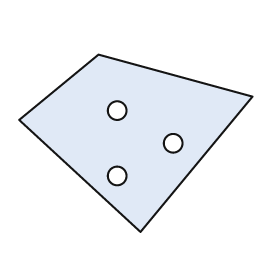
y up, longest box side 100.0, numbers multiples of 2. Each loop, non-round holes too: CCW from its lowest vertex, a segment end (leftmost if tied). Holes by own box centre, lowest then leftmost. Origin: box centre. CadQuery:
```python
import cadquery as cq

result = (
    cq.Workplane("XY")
    .moveTo(2.0, -38.0)
    .lineTo(50.0, 20.0)
    .lineTo(-16.0, 38.0)
    .lineTo(-50.0, 10.0)
    .close()
    .moveTo(-8.0, -14.0)
    .circle(4.0)
    .moveTo(16.0, 0.0)
    .circle(4.0)
    .moveTo(-8.0, 14.0)
    .circle(4.0)
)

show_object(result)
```